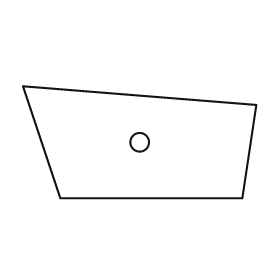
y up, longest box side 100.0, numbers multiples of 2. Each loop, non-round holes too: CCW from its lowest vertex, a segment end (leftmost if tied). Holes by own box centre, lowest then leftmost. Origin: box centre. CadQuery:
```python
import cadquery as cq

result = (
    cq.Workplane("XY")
    .moveTo(-34.0, -24.0)
    .lineTo(44.0, -24.0)
    .lineTo(50.0, 16.0)
    .lineTo(-50.0, 24.0)
    .close()
    .moveTo(0.0, 0.0)
    .circle(4.0)
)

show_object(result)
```